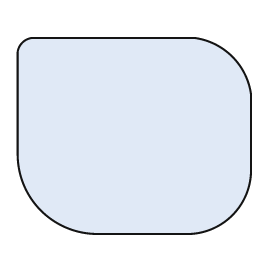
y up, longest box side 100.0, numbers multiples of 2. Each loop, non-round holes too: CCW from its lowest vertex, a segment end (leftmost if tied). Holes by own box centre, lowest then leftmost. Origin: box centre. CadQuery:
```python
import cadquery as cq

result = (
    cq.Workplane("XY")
    .moveTo(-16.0, -42.0)
    .lineTo(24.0, -42.0)
    .threePointArc((42.0, -34.0), (50.0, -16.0))
    .lineTo(50.0, 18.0)
    .threePointArc((42.0, 34.0), (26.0, 42.0))
    .lineTo(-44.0, 42.0)
    .threePointArc((-48.0, 40.0), (-50.0, 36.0))
    .lineTo(-50.0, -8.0)
    .threePointArc((-40.0, -32.0), (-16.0, -42.0))
    .close()
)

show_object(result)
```